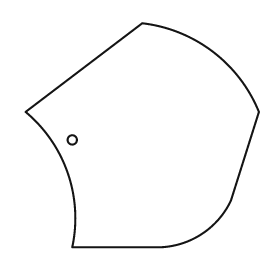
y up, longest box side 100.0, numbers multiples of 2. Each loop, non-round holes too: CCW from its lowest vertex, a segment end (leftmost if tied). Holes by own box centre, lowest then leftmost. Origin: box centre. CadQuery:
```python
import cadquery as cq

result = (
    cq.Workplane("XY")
    .moveTo(-30.0, -48.0)
    .lineTo(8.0, -48.0)
    .threePointArc((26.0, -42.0), (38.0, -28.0))
    .lineTo(50.0, 10.0)
    .threePointArc((30.0, 36.0), (0.0, 48.0))
    .lineTo(-50.0, 10.0)
    .threePointArc((-32.0, -16.0), (-30.0, -48.0))
    .close()
    .moveTo(-30.0, -2.0)
    .circle(2.0)
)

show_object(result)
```